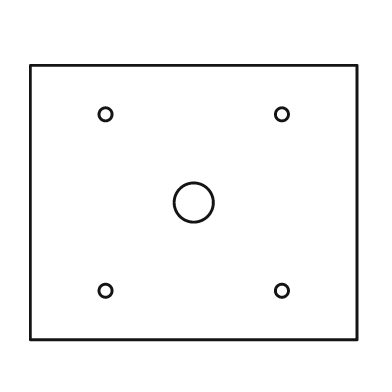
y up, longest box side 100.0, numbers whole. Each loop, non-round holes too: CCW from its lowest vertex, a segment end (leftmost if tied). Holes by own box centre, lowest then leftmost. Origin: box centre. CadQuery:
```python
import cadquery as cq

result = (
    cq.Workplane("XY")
    .moveTo(-50.0, -42.0)
    .lineTo(50.0, -42.0)
    .lineTo(50.0, 42.0)
    .lineTo(-50.0, 42.0)
    .close()
    .moveTo(-27.0, -27.0)
    .circle(2.0)
    .moveTo(27.0, -27.0)
    .circle(2.0)
    .moveTo(0.0, 0.0)
    .circle(6.0)
    .moveTo(-27.0, 27.0)
    .circle(2.0)
    .moveTo(27.0, 27.0)
    .circle(2.0)
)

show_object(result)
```